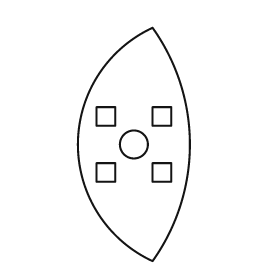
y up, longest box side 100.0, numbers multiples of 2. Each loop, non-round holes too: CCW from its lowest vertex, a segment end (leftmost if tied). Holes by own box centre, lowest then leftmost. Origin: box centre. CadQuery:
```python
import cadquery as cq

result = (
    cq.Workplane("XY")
    .moveTo(8.0, -50.0)
    .threePointArc((24.0, 0.0), (8.0, 50.0))
    .threePointArc((-24.0, 0.0), (8.0, -50.0))
    .close()
    .moveTo(-16.0, -16.0)
    .lineTo(-8.0, -16.0)
    .lineTo(-8.0, -8.0)
    .lineTo(-16.0, -8.0)
    .close()
    .moveTo(8.0, -16.0)
    .lineTo(16.0, -16.0)
    .lineTo(16.0, -8.0)
    .lineTo(8.0, -8.0)
    .close()
    .moveTo(0.0, 0.0)
    .circle(6.0)
    .moveTo(-16.0, 8.0)
    .lineTo(-8.0, 8.0)
    .lineTo(-8.0, 16.0)
    .lineTo(-16.0, 16.0)
    .close()
    .moveTo(8.0, 8.0)
    .lineTo(16.0, 8.0)
    .lineTo(16.0, 16.0)
    .lineTo(8.0, 16.0)
    .close()
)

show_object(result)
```